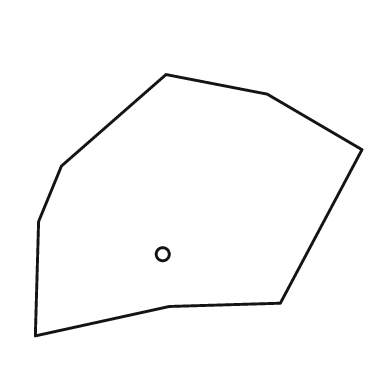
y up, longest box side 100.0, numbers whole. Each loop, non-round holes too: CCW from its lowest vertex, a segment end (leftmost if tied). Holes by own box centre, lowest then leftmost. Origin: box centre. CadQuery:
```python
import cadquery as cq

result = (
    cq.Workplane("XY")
    .moveTo(-50.0, -40.0)
    .lineTo(-9.0, -31.0)
    .lineTo(25.0, -30.0)
    .lineTo(50.0, 17.0)
    .lineTo(21.0, 34.0)
    .lineTo(-10.0, 40.0)
    .lineTo(-42.0, 12.0)
    .lineTo(-49.0, -5.0)
    .close()
    .moveTo(-11.0, -15.0)
    .circle(2.0)
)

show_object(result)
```